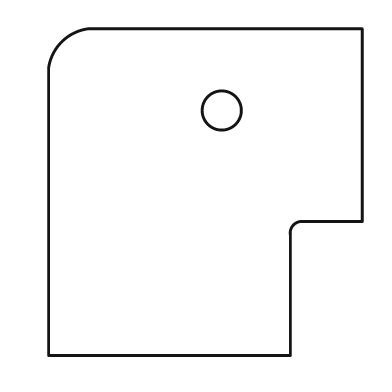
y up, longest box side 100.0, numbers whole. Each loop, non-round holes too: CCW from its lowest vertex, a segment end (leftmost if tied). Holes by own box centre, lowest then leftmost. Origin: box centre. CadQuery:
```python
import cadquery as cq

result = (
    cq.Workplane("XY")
    .moveTo(-48.0, -50.0)
    .lineTo(26.0, -50.0)
    .lineTo(26.0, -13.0)
    .threePointArc((27.0, -10.0), (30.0, -9.0))
    .lineTo(48.0, -9.0)
    .lineTo(48.0, 50.0)
    .lineTo(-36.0, 50.0)
    .threePointArc((-44.0, 46.0), (-48.0, 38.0))
    .close()
    .moveTo(5.0, 25.0)
    .circle(6.0)
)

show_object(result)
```